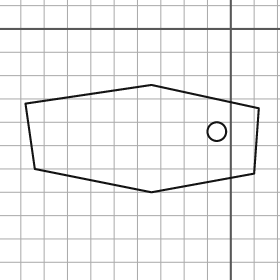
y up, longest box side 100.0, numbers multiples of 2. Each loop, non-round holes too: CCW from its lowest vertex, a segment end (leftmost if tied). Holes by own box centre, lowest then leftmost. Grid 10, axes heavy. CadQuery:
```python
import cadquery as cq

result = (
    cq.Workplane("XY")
    .moveTo(-34.0, -70.0)
    .lineTo(10.0, -62.0)
    .lineTo(12.0, -34.0)
    .lineTo(-34.0, -24.0)
    .lineTo(-88.0, -32.0)
    .lineTo(-84.0, -60.0)
    .close()
    .moveTo(-6.0, -44.0)
    .circle(4.0)
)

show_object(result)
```